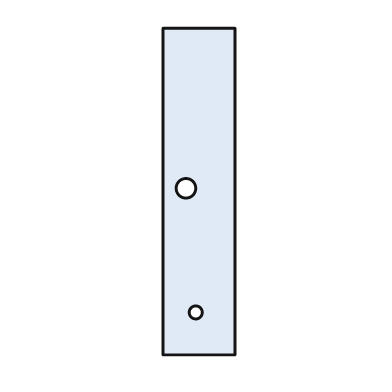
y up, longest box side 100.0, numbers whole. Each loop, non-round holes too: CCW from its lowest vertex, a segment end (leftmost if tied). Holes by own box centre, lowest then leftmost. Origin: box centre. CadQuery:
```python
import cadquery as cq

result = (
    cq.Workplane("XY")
    .moveTo(-11.0, -50.0)
    .lineTo(11.0, -50.0)
    .lineTo(11.0, 50.0)
    .lineTo(-11.0, 50.0)
    .close()
    .moveTo(-1.0, -37.0)
    .circle(2.0)
    .moveTo(-4.0, 1.0)
    .circle(3.0)
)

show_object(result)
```